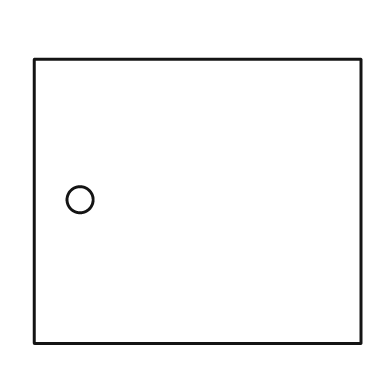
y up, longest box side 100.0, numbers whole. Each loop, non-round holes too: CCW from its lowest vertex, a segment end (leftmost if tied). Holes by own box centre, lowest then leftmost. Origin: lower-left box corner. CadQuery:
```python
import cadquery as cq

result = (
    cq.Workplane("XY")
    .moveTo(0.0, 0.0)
    .lineTo(100.0, 0.0)
    .lineTo(100.0, 87.0)
    .lineTo(0.0, 87.0)
    .close()
    .moveTo(14.0, 44.0)
    .circle(4.0)
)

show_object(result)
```